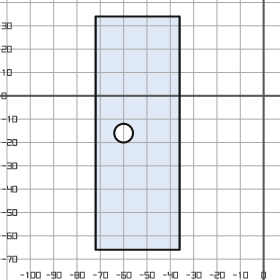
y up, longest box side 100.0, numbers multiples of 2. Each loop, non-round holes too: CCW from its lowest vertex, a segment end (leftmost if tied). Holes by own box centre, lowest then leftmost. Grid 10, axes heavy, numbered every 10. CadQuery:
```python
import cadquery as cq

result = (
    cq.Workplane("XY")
    .moveTo(-72.0, -66.0)
    .lineTo(-36.0, -66.0)
    .lineTo(-36.0, 34.0)
    .lineTo(-72.0, 34.0)
    .close()
    .moveTo(-60.0, -16.0)
    .circle(4.0)
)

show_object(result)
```